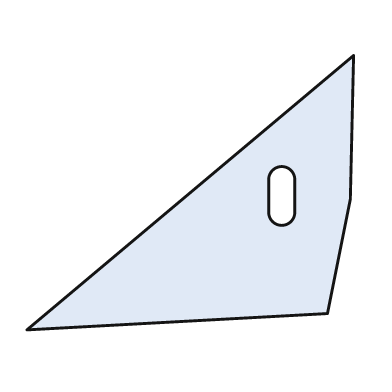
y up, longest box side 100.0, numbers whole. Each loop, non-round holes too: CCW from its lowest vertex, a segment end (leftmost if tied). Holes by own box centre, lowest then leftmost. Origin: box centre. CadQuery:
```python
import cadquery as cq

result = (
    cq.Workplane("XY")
    .moveTo(-50.0, -42.0)
    .lineTo(42.0, -37.0)
    .lineTo(49.0, -2.0)
    .lineTo(50.0, 42.0)
    .close()
    .moveTo(24.0, -6.0)
    .threePointArc((28.0, -10.0), (32.0, -6.0))
    .lineTo(32.0, 4.0)
    .threePointArc((28.0, 8.0), (24.0, 4.0))
    .close()
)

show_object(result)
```